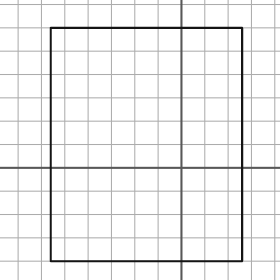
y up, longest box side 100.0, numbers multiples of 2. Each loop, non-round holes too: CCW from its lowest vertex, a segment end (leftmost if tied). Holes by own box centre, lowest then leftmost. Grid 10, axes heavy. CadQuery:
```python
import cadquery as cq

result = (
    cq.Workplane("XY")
    .moveTo(-56.0, -40.0)
    .lineTo(26.0, -40.0)
    .lineTo(26.0, 60.0)
    .lineTo(-56.0, 60.0)
    .close()
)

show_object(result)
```